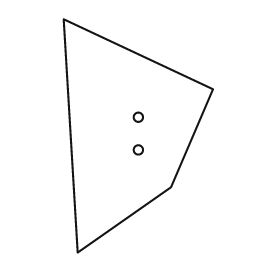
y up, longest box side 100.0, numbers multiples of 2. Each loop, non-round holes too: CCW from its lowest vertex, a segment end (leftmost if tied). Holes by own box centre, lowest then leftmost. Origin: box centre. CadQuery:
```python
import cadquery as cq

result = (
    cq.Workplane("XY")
    .moveTo(-26.0, -50.0)
    .lineTo(14.0, -22.0)
    .lineTo(32.0, 20.0)
    .lineTo(-32.0, 50.0)
    .close()
    .moveTo(0.0, -6.0)
    .circle(2.0)
    .moveTo(0.0, 8.0)
    .circle(2.0)
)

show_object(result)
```